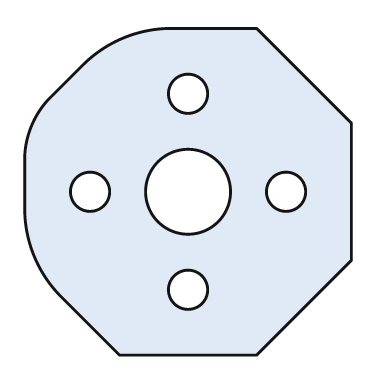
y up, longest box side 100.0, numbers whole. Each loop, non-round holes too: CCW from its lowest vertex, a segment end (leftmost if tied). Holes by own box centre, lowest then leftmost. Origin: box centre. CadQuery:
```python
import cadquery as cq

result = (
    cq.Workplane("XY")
    .moveTo(-21.0, -50.0)
    .lineTo(21.0, -50.0)
    .lineTo(50.0, -21.0)
    .lineTo(50.0, 21.0)
    .lineTo(21.0, 50.0)
    .lineTo(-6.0, 50.0)
    .threePointArc((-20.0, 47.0), (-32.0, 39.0))
    .lineTo(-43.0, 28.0)
    .threePointArc((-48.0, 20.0), (-50.0, 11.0))
    .lineTo(-50.0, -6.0)
    .threePointArc((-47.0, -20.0), (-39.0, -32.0))
    .close()
    .moveTo(0.0, -30.0)
    .circle(6.0)
    .moveTo(-30.0, 0.0)
    .circle(6.0)
    .moveTo(0.0, 0.0)
    .circle(13.0)
    .moveTo(30.0, 0.0)
    .circle(6.0)
    .moveTo(0.0, 30.0)
    .circle(6.0)
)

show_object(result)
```